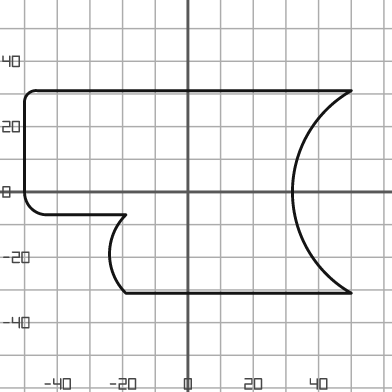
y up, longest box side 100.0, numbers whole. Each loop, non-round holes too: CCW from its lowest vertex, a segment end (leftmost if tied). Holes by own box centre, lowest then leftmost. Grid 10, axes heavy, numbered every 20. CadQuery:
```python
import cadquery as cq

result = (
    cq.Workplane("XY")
    .moveTo(-19.0, -31.0)
    .lineTo(50.0, -31.0)
    .threePointArc((32.0, 0.0), (50.0, 31.0))
    .lineTo(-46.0, 31.0)
    .threePointArc((-49.0, 30.0), (-50.0, 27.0))
    .lineTo(-50.0, 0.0)
    .threePointArc((-48.0, -5.0), (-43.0, -7.0))
    .lineTo(-19.0, -7.0)
    .threePointArc((-24.0, -19.0), (-19.0, -31.0))
    .close()
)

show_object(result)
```